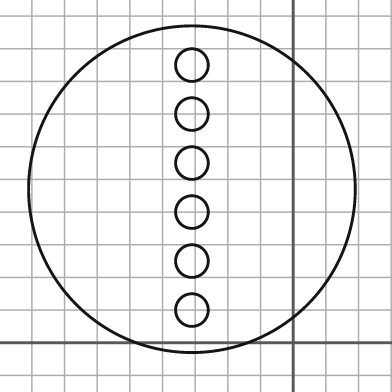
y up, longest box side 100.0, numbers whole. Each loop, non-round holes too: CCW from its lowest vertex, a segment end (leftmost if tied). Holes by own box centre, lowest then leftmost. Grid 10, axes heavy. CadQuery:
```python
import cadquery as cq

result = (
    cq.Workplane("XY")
    .moveTo(-31.0, 47.0)
    .circle(50.0)
    .moveTo(-31.0, 10.0)
    .circle(5.0)
    .moveTo(-31.0, 25.0)
    .circle(5.0)
    .moveTo(-31.0, 40.0)
    .circle(5.0)
    .moveTo(-31.0, 55.0)
    .circle(5.0)
    .moveTo(-31.0, 70.0)
    .circle(5.0)
    .moveTo(-31.0, 85.0)
    .circle(5.0)
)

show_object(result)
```